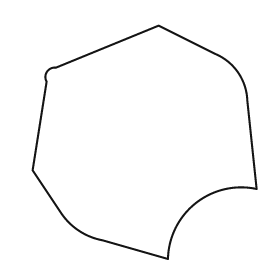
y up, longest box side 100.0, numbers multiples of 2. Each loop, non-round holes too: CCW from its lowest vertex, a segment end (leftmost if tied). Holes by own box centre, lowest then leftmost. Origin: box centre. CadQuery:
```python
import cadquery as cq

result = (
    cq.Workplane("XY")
    .moveTo(10.0, -50.0)
    .threePointArc((22.0, -26.0), (48.0, -20.0))
    .lineTo(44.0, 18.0)
    .threePointArc((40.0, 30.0), (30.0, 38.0))
    .lineTo(6.0, 50.0)
    .lineTo(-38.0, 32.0)
    .threePointArc((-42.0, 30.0), (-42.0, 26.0))
    .lineTo(-48.0, -12.0)
    .lineTo(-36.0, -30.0)
    .threePointArc((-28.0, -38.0), (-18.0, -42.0))
    .close()
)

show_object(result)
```